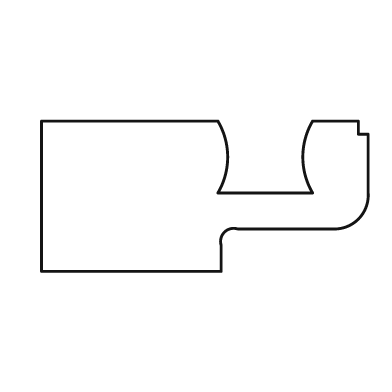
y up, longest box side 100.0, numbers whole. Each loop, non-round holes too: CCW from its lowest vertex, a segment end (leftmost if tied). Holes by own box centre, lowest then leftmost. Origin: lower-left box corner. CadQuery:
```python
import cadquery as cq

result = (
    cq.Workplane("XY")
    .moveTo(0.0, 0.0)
    .lineTo(55.0, 0.0)
    .lineTo(55.0, 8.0)
    .threePointArc((56.0, 12.0), (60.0, 13.0))
    .lineTo(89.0, 13.0)
    .threePointArc((97.0, 16.0), (100.0, 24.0))
    .lineTo(100.0, 42.0)
    .lineTo(97.0, 42.0)
    .lineTo(97.0, 46.0)
    .lineTo(83.0, 46.0)
    .threePointArc((80.0, 35.0), (83.0, 24.0))
    .lineTo(54.0, 24.0)
    .threePointArc((57.0, 35.0), (54.0, 46.0))
    .lineTo(0.0, 46.0)
    .close()
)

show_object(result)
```